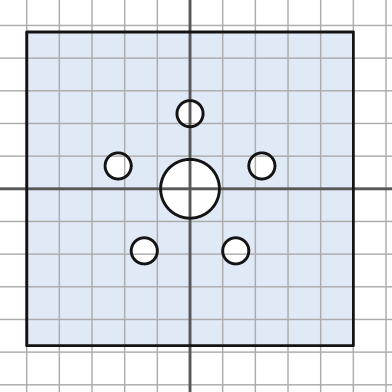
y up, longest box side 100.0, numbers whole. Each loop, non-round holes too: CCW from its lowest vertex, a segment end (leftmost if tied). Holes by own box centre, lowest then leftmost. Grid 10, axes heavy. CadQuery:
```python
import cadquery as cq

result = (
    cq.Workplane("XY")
    .moveTo(-50.0, -48.0)
    .lineTo(50.0, -48.0)
    .lineTo(50.0, 48.0)
    .lineTo(-50.0, 48.0)
    .close()
    .moveTo(-14.0, -19.0)
    .circle(4.0)
    .moveTo(14.0, -19.0)
    .circle(4.0)
    .moveTo(0.0, 0.0)
    .circle(9.0)
    .moveTo(-22.0, 7.0)
    .circle(4.0)
    .moveTo(22.0, 7.0)
    .circle(4.0)
    .moveTo(0.0, 23.0)
    .circle(4.0)
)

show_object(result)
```